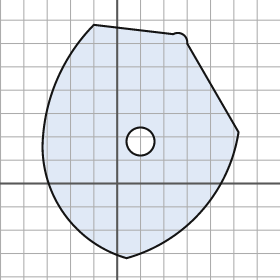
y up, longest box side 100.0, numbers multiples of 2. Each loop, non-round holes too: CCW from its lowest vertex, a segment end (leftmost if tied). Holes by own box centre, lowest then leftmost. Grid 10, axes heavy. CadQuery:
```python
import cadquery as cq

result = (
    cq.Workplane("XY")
    .moveTo(4.0, -32.0)
    .threePointArc((36.0, -12.0), (52.0, 22.0))
    .lineTo(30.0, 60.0)
    .threePointArc((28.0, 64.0), (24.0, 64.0))
    .lineTo(-10.0, 68.0)
    .threePointArc((-26.0, 44.0), (-32.0, 16.0))
    .threePointArc((-22.0, -14.0), (4.0, -32.0))
    .close()
    .moveTo(10.0, 18.0)
    .circle(6.0)
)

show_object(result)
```